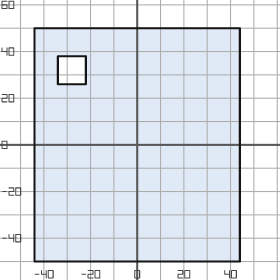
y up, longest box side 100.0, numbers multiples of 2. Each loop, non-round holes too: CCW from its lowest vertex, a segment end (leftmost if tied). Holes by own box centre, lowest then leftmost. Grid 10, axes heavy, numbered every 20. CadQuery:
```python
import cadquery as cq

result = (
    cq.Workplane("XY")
    .moveTo(-44.0, -50.0)
    .lineTo(44.0, -50.0)
    .lineTo(44.0, 50.0)
    .lineTo(-44.0, 50.0)
    .close()
    .moveTo(-34.0, 26.0)
    .lineTo(-22.0, 26.0)
    .lineTo(-22.0, 38.0)
    .lineTo(-34.0, 38.0)
    .close()
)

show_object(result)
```